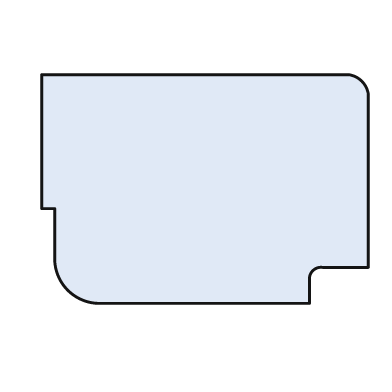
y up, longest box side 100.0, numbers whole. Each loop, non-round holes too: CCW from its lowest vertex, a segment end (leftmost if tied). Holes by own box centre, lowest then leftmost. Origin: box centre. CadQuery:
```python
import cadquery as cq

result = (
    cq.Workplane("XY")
    .moveTo(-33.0, -35.0)
    .lineTo(32.0, -35.0)
    .lineTo(32.0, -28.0)
    .threePointArc((33.0, -25.0), (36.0, -24.0))
    .lineTo(50.0, -24.0)
    .lineTo(50.0, 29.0)
    .threePointArc((48.0, 33.0), (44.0, 35.0))
    .lineTo(-50.0, 35.0)
    .lineTo(-50.0, -6.0)
    .lineTo(-46.0, -6.0)
    .lineTo(-46.0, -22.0)
    .threePointArc((-42.0, -31.0), (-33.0, -35.0))
    .close()
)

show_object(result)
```